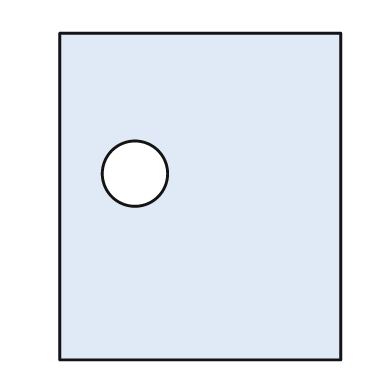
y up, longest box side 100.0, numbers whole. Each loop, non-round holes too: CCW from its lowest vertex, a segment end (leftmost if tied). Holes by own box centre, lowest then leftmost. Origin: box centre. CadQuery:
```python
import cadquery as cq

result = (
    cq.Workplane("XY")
    .moveTo(-43.0, -50.0)
    .lineTo(43.0, -50.0)
    .lineTo(43.0, 50.0)
    .lineTo(-43.0, 50.0)
    .close()
    .moveTo(-20.0, 7.0)
    .circle(10.0)
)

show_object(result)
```